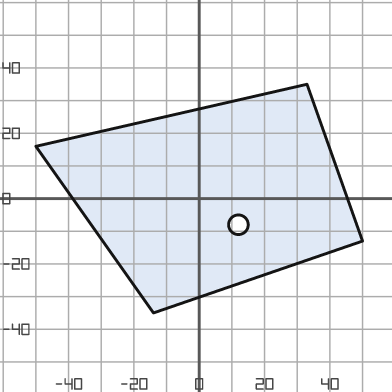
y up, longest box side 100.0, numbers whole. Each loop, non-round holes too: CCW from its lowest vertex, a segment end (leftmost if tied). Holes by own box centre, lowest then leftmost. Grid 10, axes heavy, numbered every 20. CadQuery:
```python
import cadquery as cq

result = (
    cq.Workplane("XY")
    .moveTo(-14.0, -35.0)
    .lineTo(50.0, -13.0)
    .lineTo(33.0, 35.0)
    .lineTo(-50.0, 16.0)
    .close()
    .moveTo(12.0, -8.0)
    .circle(3.0)
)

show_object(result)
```